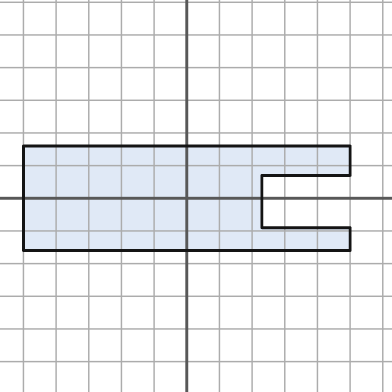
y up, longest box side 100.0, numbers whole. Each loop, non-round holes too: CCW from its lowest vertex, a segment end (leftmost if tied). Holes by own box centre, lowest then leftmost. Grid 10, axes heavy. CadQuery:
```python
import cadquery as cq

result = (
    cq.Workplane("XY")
    .moveTo(-50.0, -16.0)
    .lineTo(50.0, -16.0)
    .lineTo(50.0, -9.0)
    .lineTo(23.0, -9.0)
    .lineTo(23.0, 7.0)
    .lineTo(50.0, 7.0)
    .lineTo(50.0, 16.0)
    .lineTo(-50.0, 16.0)
    .close()
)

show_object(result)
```